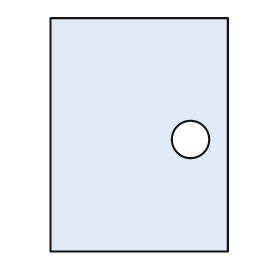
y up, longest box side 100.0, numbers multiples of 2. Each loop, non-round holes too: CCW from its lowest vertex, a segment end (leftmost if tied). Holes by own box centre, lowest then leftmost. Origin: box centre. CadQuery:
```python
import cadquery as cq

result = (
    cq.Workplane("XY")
    .moveTo(-38.0, -50.0)
    .lineTo(38.0, -50.0)
    .lineTo(38.0, 50.0)
    .lineTo(-38.0, 50.0)
    .close()
    .moveTo(22.0, -2.0)
    .circle(8.0)
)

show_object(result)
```